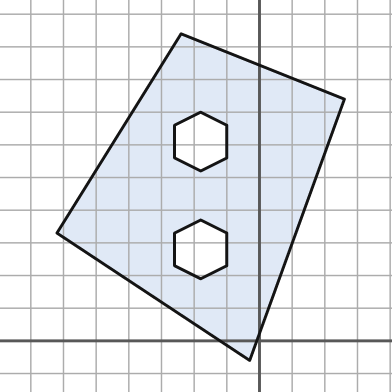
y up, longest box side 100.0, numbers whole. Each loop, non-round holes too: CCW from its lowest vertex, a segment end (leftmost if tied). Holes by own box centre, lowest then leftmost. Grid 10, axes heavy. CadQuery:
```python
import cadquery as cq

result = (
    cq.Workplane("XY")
    .moveTo(-3.0, -6.0)
    .lineTo(26.0, 74.0)
    .lineTo(-24.0, 94.0)
    .lineTo(-62.0, 33.0)
    .close()
    .moveTo(-18.0, 19.0)
    .lineTo(-10.0, 23.0)
    .lineTo(-10.0, 33.0)
    .lineTo(-18.0, 37.0)
    .lineTo(-26.0, 33.0)
    .lineTo(-26.0, 23.0)
    .close()
    .moveTo(-18.0, 52.0)
    .lineTo(-10.0, 56.0)
    .lineTo(-10.0, 66.0)
    .lineTo(-18.0, 70.0)
    .lineTo(-26.0, 66.0)
    .lineTo(-26.0, 56.0)
    .close()
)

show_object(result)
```